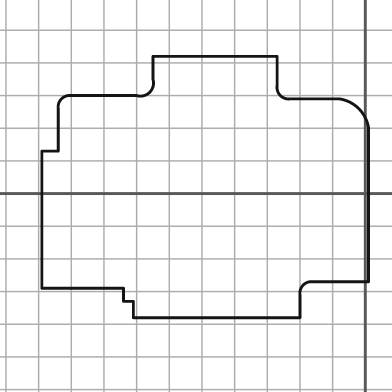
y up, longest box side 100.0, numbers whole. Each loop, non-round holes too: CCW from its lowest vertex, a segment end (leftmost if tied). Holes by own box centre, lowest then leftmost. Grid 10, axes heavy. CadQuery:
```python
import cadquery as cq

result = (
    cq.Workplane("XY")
    .moveTo(-71.0, -38.0)
    .lineTo(-20.0, -38.0)
    .lineTo(-20.0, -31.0)
    .threePointArc((-19.0, -28.0), (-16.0, -27.0))
    .lineTo(1.0, -27.0)
    .lineTo(1.0, 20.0)
    .threePointArc((-2.0, 26.0), (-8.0, 29.0))
    .lineTo(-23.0, 29.0)
    .threePointArc((-26.0, 30.0), (-27.0, 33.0))
    .lineTo(-27.0, 42.0)
    .lineTo(-65.0, 42.0)
    .lineTo(-65.0, 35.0)
    .threePointArc((-66.0, 31.0), (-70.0, 30.0))
    .lineTo(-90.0, 30.0)
    .threePointArc((-93.0, 29.0), (-94.0, 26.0))
    .lineTo(-94.0, 13.0)
    .lineTo(-99.0, 13.0)
    .lineTo(-99.0, -29.0)
    .lineTo(-74.0, -29.0)
    .lineTo(-74.0, -33.0)
    .lineTo(-71.0, -33.0)
    .close()
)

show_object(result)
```